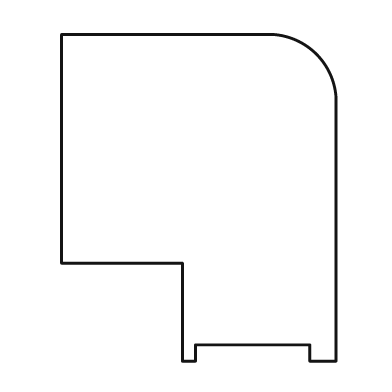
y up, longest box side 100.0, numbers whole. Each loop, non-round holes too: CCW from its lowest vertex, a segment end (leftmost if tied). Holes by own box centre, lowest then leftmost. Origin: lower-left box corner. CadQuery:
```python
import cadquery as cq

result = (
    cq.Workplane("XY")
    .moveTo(37.0, 0.0)
    .lineTo(41.0, 0.0)
    .lineTo(41.0, 5.0)
    .lineTo(76.0, 5.0)
    .lineTo(76.0, 0.0)
    .lineTo(84.0, 0.0)
    .lineTo(84.0, 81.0)
    .threePointArc((78.0, 94.0), (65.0, 100.0))
    .lineTo(0.0, 100.0)
    .lineTo(0.0, 30.0)
    .lineTo(37.0, 30.0)
    .close()
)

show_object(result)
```